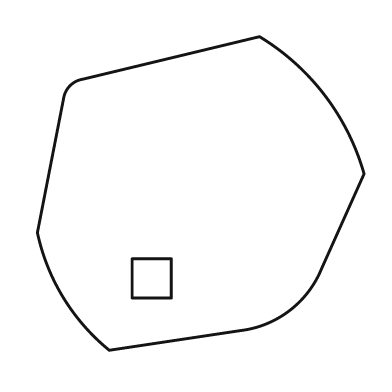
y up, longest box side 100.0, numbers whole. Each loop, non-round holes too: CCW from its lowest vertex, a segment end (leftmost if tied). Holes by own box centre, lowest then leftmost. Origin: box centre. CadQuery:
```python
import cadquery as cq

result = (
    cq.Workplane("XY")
    .moveTo(-28.0, -48.0)
    .lineTo(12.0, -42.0)
    .threePointArc((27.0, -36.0), (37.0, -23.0))
    .lineTo(50.0, 6.0)
    .threePointArc((38.0, 30.0), (18.0, 48.0))
    .lineTo(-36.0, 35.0)
    .threePointArc((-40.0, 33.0), (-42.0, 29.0))
    .lineTo(-50.0, -12.0)
    .threePointArc((-42.0, -32.0), (-28.0, -48.0))
    .close()
    .moveTo(-21.0, -32.0)
    .lineTo(-9.0, -32.0)
    .lineTo(-9.0, -20.0)
    .lineTo(-21.0, -20.0)
    .close()
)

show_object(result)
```